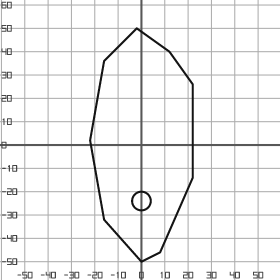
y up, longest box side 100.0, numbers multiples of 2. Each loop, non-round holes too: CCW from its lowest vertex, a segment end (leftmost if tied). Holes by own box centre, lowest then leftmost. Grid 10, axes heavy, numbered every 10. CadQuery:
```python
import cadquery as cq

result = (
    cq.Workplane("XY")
    .moveTo(0.0, -50.0)
    .lineTo(8.0, -46.0)
    .lineTo(22.0, -14.0)
    .lineTo(22.0, 26.0)
    .lineTo(12.0, 40.0)
    .lineTo(-2.0, 50.0)
    .lineTo(-16.0, 36.0)
    .lineTo(-22.0, 2.0)
    .lineTo(-16.0, -32.0)
    .close()
    .moveTo(0.0, -24.0)
    .circle(4.0)
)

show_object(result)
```